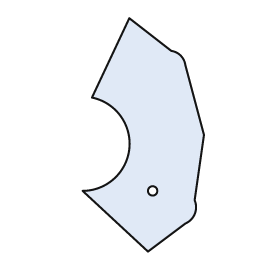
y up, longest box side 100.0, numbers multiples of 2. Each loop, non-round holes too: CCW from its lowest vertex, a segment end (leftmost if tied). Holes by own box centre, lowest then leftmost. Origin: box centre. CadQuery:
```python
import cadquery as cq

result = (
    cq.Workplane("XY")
    .moveTo(2.0, -50.0)
    .lineTo(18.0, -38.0)
    .threePointArc((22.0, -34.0), (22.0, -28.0))
    .lineTo(26.0, 0.0)
    .lineTo(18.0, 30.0)
    .threePointArc((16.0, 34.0), (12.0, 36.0))
    .lineTo(-6.0, 50.0)
    .lineTo(-22.0, 16.0)
    .threePointArc((-6.0, -6.0), (-26.0, -24.0))
    .close()
    .moveTo(4.0, -24.0)
    .circle(2.0)
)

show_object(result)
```